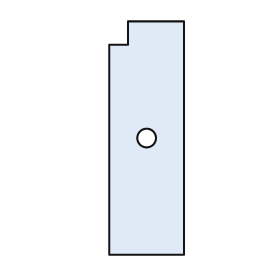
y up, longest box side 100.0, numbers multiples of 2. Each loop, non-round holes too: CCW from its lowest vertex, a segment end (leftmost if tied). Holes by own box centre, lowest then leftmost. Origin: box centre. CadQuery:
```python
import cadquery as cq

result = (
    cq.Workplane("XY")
    .moveTo(-16.0, -50.0)
    .lineTo(16.0, -50.0)
    .lineTo(16.0, 50.0)
    .lineTo(-8.0, 50.0)
    .lineTo(-8.0, 40.0)
    .lineTo(-16.0, 40.0)
    .close()
    .moveTo(0.0, 0.0)
    .circle(4.0)
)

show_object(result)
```